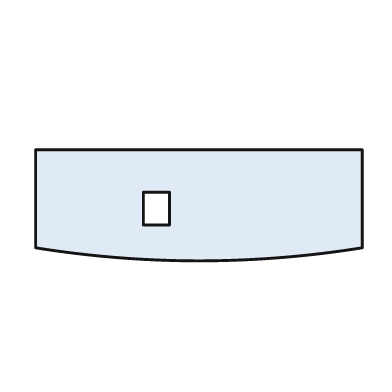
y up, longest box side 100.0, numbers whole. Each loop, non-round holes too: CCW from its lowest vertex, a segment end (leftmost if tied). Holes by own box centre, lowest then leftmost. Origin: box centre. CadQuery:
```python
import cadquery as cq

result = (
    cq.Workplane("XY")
    .moveTo(-50.0, -13.0)
    .threePointArc((0.0, -17.0), (50.0, -13.0))
    .lineTo(50.0, 17.0)
    .lineTo(-50.0, 17.0)
    .close()
    .moveTo(-17.0, -6.0)
    .lineTo(-9.0, -6.0)
    .lineTo(-9.0, 4.0)
    .lineTo(-17.0, 4.0)
    .close()
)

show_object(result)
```